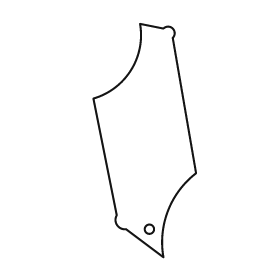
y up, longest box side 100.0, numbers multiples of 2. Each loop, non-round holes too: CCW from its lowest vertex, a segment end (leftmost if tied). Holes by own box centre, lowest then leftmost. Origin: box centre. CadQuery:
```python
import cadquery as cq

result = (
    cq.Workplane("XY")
    .moveTo(8.0, -50.0)
    .threePointArc((10.0, -30.0), (22.0, -14.0))
    .lineTo(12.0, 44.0)
    .threePointArc((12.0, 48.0), (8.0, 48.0))
    .lineTo(-2.0, 50.0)
    .threePointArc((-6.0, 30.0), (-22.0, 18.0))
    .lineTo(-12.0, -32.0)
    .threePointArc((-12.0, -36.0), (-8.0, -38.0))
    .close()
    .moveTo(2.0, -38.0)
    .circle(2.0)
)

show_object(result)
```